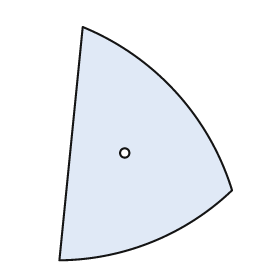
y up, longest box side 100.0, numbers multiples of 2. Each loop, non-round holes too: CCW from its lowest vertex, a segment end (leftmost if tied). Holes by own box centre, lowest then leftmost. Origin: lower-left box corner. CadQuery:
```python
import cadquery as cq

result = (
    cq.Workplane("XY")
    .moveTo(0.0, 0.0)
    .threePointArc((40.0, 8.0), (74.0, 30.0))
    .threePointArc((50.0, 72.0), (10.0, 100.0))
    .close()
    .moveTo(28.0, 46.0)
    .circle(2.0)
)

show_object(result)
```